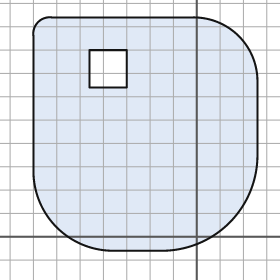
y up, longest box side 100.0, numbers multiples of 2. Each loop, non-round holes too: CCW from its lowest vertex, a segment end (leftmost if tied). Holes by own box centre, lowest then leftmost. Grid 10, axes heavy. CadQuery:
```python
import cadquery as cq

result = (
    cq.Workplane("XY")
    .moveTo(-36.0, -6.0)
    .lineTo(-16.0, -6.0)
    .threePointArc((14.0, 6.0), (26.0, 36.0))
    .lineTo(26.0, 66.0)
    .threePointArc((18.0, 86.0), (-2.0, 94.0))
    .lineTo(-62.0, 94.0)
    .threePointArc((-68.0, 92.0), (-70.0, 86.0))
    .lineTo(-70.0, 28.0)
    .threePointArc((-60.0, 4.0), (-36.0, -6.0))
    .close()
    .moveTo(-46.0, 64.0)
    .lineTo(-30.0, 64.0)
    .lineTo(-30.0, 80.0)
    .lineTo(-46.0, 80.0)
    .close()
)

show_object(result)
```